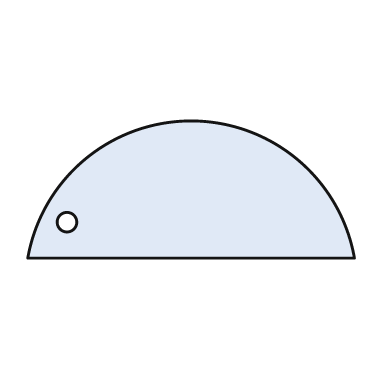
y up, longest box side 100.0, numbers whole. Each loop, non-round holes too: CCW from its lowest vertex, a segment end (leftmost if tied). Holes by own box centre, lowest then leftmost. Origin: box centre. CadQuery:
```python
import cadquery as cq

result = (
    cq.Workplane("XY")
    .moveTo(-50.0, -21.0)
    .lineTo(50.0, -21.0)
    .threePointArc((0.0, 21.0), (-50.0, -21.0))
    .close()
    .moveTo(-38.0, -10.0)
    .circle(3.0)
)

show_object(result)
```